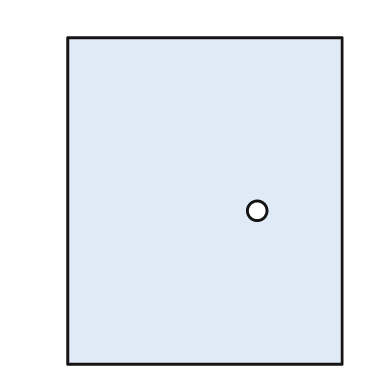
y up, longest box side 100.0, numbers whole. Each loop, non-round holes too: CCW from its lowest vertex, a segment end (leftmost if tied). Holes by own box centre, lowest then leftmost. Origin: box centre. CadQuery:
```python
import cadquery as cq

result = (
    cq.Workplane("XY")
    .moveTo(-42.0, -50.0)
    .lineTo(42.0, -50.0)
    .lineTo(42.0, 50.0)
    .lineTo(-42.0, 50.0)
    .close()
    .moveTo(16.0, -3.0)
    .circle(3.0)
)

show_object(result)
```